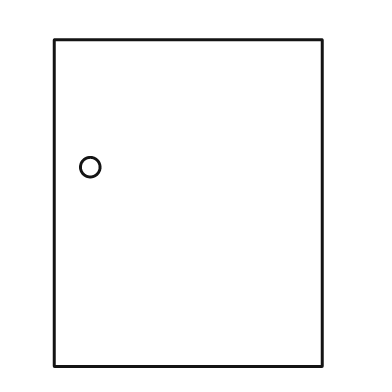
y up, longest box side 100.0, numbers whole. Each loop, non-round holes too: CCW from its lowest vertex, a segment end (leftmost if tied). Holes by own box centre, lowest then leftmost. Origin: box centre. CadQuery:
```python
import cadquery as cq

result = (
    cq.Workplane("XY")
    .moveTo(-41.0, -50.0)
    .lineTo(41.0, -50.0)
    .lineTo(41.0, 50.0)
    .lineTo(-41.0, 50.0)
    .close()
    .moveTo(-30.0, 11.0)
    .circle(3.0)
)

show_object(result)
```